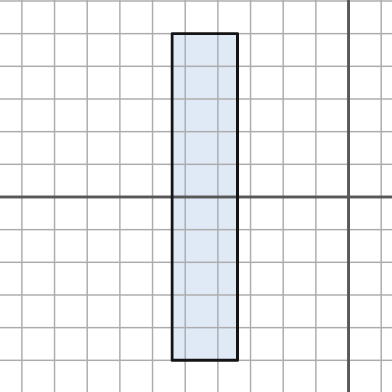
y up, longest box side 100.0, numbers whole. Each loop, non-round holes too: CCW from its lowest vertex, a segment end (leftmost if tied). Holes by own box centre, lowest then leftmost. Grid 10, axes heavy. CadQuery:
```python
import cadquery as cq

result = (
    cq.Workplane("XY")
    .moveTo(-54.0, -50.0)
    .lineTo(-34.0, -50.0)
    .lineTo(-34.0, 50.0)
    .lineTo(-54.0, 50.0)
    .close()
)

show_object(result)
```